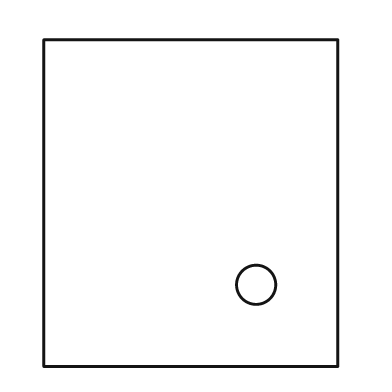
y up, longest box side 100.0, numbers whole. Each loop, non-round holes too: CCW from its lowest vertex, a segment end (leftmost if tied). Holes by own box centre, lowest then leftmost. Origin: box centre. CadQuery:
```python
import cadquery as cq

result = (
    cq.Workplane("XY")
    .moveTo(-45.0, -50.0)
    .lineTo(45.0, -50.0)
    .lineTo(45.0, 50.0)
    .lineTo(-45.0, 50.0)
    .close()
    .moveTo(20.0, -25.0)
    .circle(6.0)
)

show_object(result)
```